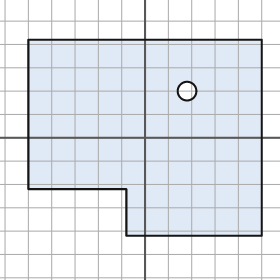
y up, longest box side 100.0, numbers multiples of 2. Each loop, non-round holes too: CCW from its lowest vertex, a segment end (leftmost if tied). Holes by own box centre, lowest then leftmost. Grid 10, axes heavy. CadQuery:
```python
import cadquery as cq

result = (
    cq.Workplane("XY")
    .moveTo(-8.0, -42.0)
    .lineTo(50.0, -42.0)
    .lineTo(50.0, 42.0)
    .lineTo(-50.0, 42.0)
    .lineTo(-50.0, -22.0)
    .lineTo(-8.0, -22.0)
    .close()
    .moveTo(18.0, 20.0)
    .circle(4.0)
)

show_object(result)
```